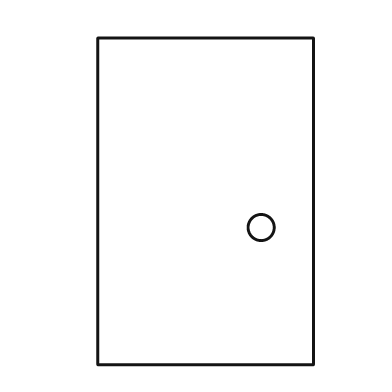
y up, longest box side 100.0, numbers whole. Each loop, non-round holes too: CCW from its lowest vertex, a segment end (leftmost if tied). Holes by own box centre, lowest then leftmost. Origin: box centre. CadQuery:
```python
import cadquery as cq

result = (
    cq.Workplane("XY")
    .moveTo(-33.0, -50.0)
    .lineTo(33.0, -50.0)
    .lineTo(33.0, 50.0)
    .lineTo(-33.0, 50.0)
    .close()
    .moveTo(17.0, -8.0)
    .circle(4.0)
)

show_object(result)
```